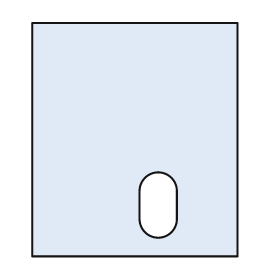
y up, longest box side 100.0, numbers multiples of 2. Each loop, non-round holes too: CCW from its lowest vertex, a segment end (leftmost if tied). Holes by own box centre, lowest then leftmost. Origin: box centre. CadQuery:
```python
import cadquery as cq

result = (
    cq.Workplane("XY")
    .moveTo(-44.0, -50.0)
    .lineTo(44.0, -50.0)
    .lineTo(44.0, 50.0)
    .lineTo(-44.0, 50.0)
    .close()
    .moveTo(2.0, -34.0)
    .threePointArc((10.0, -42.0), (18.0, -34.0))
    .lineTo(18.0, -22.0)
    .threePointArc((10.0, -14.0), (2.0, -22.0))
    .close()
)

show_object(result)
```